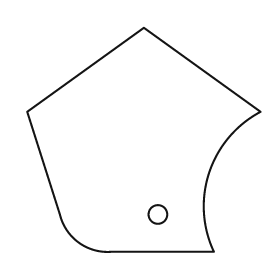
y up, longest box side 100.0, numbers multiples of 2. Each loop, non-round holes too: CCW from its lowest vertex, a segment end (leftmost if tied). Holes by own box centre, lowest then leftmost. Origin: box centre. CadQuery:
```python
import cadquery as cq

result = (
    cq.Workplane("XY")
    .moveTo(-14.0, -48.0)
    .lineTo(30.0, -48.0)
    .threePointArc((28.0, -14.0), (50.0, 12.0))
    .lineTo(0.0, 48.0)
    .lineTo(-50.0, 12.0)
    .lineTo(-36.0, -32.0)
    .threePointArc((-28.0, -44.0), (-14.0, -48.0))
    .close()
    .moveTo(6.0, -32.0)
    .circle(4.0)
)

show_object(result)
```